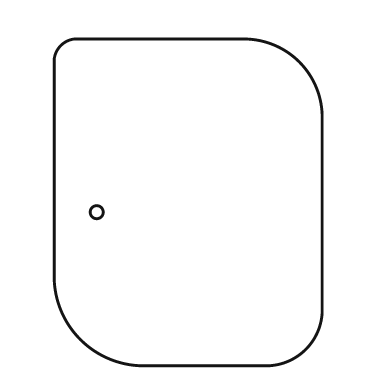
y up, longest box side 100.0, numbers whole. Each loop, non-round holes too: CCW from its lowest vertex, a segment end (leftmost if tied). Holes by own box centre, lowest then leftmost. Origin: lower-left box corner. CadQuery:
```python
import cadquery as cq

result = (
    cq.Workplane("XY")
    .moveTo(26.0, 0.0)
    .lineTo(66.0, 0.0)
    .threePointArc((77.0, 5.0), (82.0, 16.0))
    .lineTo(82.0, 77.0)
    .threePointArc((75.0, 93.0), (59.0, 100.0))
    .lineTo(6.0, 100.0)
    .threePointArc((2.0, 98.0), (0.0, 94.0))
    .lineTo(0.0, 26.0)
    .threePointArc((8.0, 8.0), (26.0, 0.0))
    .close()
    .moveTo(13.0, 47.0)
    .circle(2.0)
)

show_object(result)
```